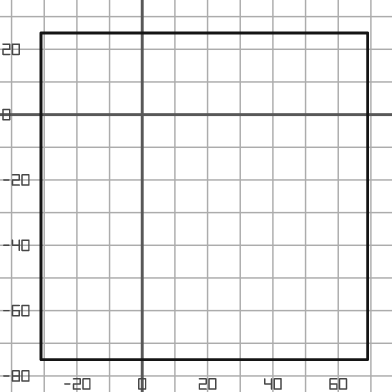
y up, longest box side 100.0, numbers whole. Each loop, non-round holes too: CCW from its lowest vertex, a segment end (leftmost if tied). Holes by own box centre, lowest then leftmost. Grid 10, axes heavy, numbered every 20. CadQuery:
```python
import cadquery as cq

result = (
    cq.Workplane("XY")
    .moveTo(-31.0, -75.0)
    .lineTo(69.0, -75.0)
    .lineTo(69.0, 25.0)
    .lineTo(-31.0, 25.0)
    .close()
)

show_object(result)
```